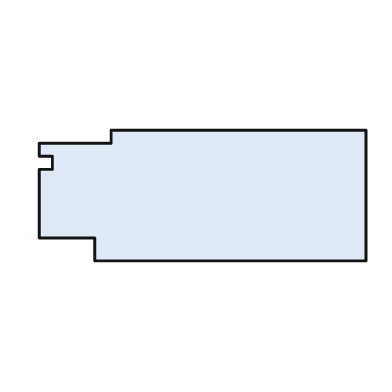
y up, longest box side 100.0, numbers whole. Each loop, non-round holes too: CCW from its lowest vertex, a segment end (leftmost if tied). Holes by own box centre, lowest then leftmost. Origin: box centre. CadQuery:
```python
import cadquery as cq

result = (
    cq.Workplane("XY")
    .moveTo(-33.0, -20.0)
    .lineTo(50.0, -20.0)
    .lineTo(50.0, 20.0)
    .lineTo(-28.0, 20.0)
    .lineTo(-28.0, 16.0)
    .lineTo(-50.0, 16.0)
    .lineTo(-50.0, 12.0)
    .lineTo(-46.0, 12.0)
    .lineTo(-46.0, 8.0)
    .lineTo(-50.0, 8.0)
    .lineTo(-50.0, -13.0)
    .lineTo(-33.0, -13.0)
    .close()
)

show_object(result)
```